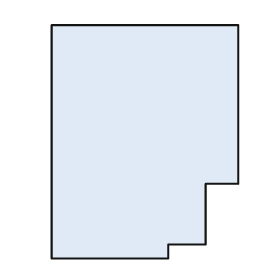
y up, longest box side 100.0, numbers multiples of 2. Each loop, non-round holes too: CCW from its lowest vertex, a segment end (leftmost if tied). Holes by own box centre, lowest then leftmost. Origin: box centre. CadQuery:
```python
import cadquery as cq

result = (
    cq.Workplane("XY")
    .moveTo(-40.0, -50.0)
    .lineTo(10.0, -50.0)
    .lineTo(10.0, -44.0)
    .lineTo(26.0, -44.0)
    .lineTo(26.0, -18.0)
    .lineTo(40.0, -18.0)
    .lineTo(40.0, 50.0)
    .lineTo(-40.0, 50.0)
    .close()
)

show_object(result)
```